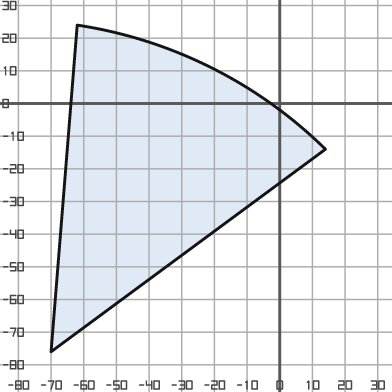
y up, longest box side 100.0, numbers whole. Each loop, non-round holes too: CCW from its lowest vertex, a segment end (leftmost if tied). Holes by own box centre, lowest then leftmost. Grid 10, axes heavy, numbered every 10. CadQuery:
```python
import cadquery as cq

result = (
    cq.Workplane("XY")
    .moveTo(-70.0, -76.0)
    .lineTo(14.0, -14.0)
    .threePointArc((-21.0, 11.0), (-62.0, 24.0))
    .close()
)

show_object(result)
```